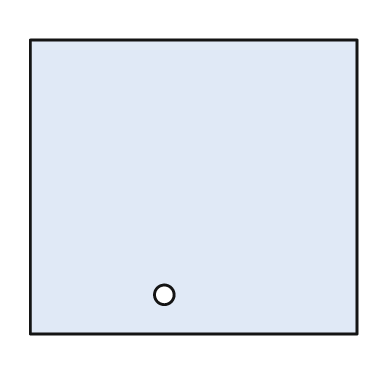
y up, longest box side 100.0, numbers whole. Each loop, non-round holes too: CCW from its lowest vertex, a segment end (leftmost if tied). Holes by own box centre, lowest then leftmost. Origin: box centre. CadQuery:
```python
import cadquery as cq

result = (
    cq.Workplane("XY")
    .moveTo(-50.0, -45.0)
    .lineTo(50.0, -45.0)
    .lineTo(50.0, 45.0)
    .lineTo(-50.0, 45.0)
    .close()
    .moveTo(-9.0, -33.0)
    .circle(3.0)
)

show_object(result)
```